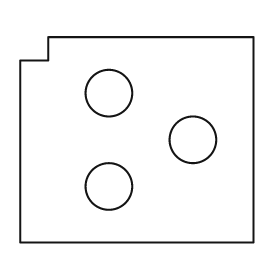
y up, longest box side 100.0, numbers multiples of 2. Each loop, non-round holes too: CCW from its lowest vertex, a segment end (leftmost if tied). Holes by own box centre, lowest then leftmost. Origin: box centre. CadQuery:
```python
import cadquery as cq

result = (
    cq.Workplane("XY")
    .moveTo(-50.0, -44.0)
    .lineTo(50.0, -44.0)
    .lineTo(50.0, 44.0)
    .lineTo(-38.0, 44.0)
    .lineTo(-38.0, 34.0)
    .lineTo(-50.0, 34.0)
    .close()
    .moveTo(-12.0, -20.0)
    .circle(10.0)
    .moveTo(24.0, 0.0)
    .circle(10.0)
    .moveTo(-12.0, 20.0)
    .circle(10.0)
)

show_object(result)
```